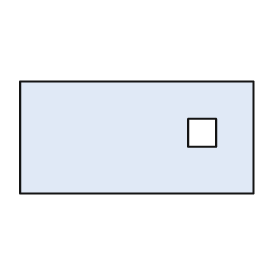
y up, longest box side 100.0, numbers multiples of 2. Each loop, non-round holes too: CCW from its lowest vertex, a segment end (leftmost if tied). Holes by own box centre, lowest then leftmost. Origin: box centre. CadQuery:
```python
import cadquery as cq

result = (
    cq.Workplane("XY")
    .moveTo(-50.0, -24.0)
    .lineTo(50.0, -24.0)
    .lineTo(50.0, 24.0)
    .lineTo(-50.0, 24.0)
    .close()
    .moveTo(22.0, -4.0)
    .lineTo(34.0, -4.0)
    .lineTo(34.0, 8.0)
    .lineTo(22.0, 8.0)
    .close()
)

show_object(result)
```